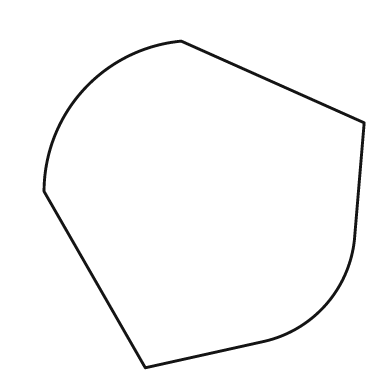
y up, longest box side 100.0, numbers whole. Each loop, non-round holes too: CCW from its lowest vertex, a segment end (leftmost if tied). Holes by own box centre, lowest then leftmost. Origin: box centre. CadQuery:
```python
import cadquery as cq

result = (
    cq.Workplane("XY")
    .moveTo(-18.0, -50.0)
    .lineTo(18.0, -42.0)
    .threePointArc((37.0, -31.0), (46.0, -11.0))
    .lineTo(49.0, 25.0)
    .lineTo(-7.0, 50.0)
    .threePointArc((-37.0, 35.0), (-49.0, 4.0))
    .close()
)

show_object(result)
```